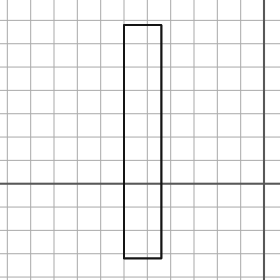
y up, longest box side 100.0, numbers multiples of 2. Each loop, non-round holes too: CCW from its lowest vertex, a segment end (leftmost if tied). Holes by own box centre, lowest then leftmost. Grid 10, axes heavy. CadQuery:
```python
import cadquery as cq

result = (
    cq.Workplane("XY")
    .moveTo(-60.0, -32.0)
    .lineTo(-44.0, -32.0)
    .lineTo(-44.0, 68.0)
    .lineTo(-60.0, 68.0)
    .close()
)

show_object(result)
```